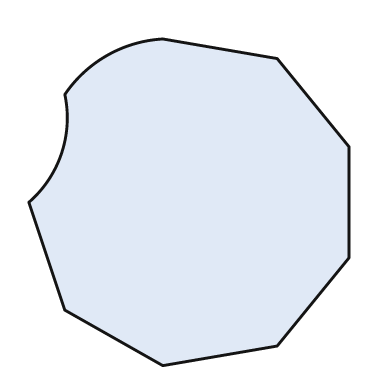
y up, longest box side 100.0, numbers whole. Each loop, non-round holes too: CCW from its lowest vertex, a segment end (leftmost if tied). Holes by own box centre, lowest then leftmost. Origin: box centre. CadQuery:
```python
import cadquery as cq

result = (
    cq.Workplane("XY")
    .moveTo(-8.0, -50.0)
    .lineTo(27.0, -44.0)
    .lineTo(49.0, -17.0)
    .lineTo(49.0, 17.0)
    .lineTo(27.0, 44.0)
    .lineTo(-8.0, 50.0)
    .threePointArc((-25.0, 45.0), (-38.0, 33.0))
    .threePointArc((-39.0, 15.0), (-49.0, 0.0))
    .lineTo(-38.0, -33.0)
    .close()
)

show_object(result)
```